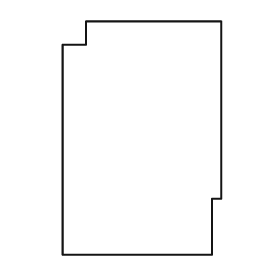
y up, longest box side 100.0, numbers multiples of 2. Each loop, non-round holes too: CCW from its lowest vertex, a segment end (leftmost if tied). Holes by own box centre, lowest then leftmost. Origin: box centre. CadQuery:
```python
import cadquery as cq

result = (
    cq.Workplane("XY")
    .moveTo(-34.0, -50.0)
    .lineTo(30.0, -50.0)
    .lineTo(30.0, -26.0)
    .lineTo(34.0, -26.0)
    .lineTo(34.0, 50.0)
    .lineTo(-24.0, 50.0)
    .lineTo(-24.0, 40.0)
    .lineTo(-34.0, 40.0)
    .close()
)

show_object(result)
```